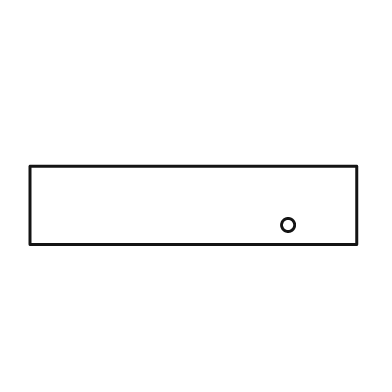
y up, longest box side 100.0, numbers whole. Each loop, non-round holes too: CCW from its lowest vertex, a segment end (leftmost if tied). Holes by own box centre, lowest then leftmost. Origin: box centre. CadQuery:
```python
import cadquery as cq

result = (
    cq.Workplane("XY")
    .moveTo(-50.0, -12.0)
    .lineTo(50.0, -12.0)
    .lineTo(50.0, 12.0)
    .lineTo(-50.0, 12.0)
    .close()
    .moveTo(29.0, -6.0)
    .circle(2.0)
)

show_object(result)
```